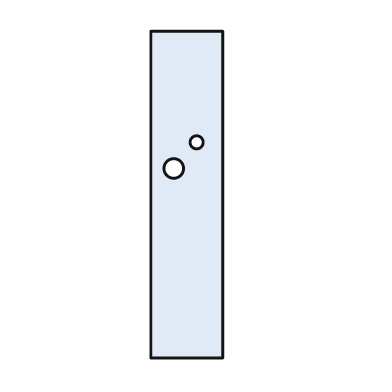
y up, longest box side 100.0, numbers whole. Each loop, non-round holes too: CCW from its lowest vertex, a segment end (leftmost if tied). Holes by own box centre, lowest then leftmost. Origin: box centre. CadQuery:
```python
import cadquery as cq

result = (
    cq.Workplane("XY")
    .moveTo(-11.0, -50.0)
    .lineTo(11.0, -50.0)
    .lineTo(11.0, 50.0)
    .lineTo(-11.0, 50.0)
    .close()
    .moveTo(-4.0, 8.0)
    .circle(3.0)
    .moveTo(3.0, 16.0)
    .circle(2.0)
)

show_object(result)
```